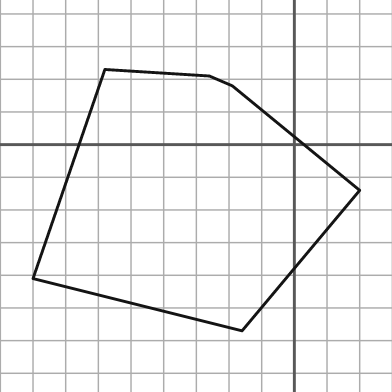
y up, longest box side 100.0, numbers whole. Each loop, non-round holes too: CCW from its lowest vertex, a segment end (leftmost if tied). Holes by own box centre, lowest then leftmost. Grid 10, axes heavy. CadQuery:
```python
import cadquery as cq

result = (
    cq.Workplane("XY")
    .moveTo(-16.0, -57.0)
    .lineTo(20.0, -14.0)
    .lineTo(-19.0, 18.0)
    .lineTo(-26.0, 21.0)
    .lineTo(-58.0, 23.0)
    .lineTo(-80.0, -41.0)
    .close()
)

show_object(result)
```